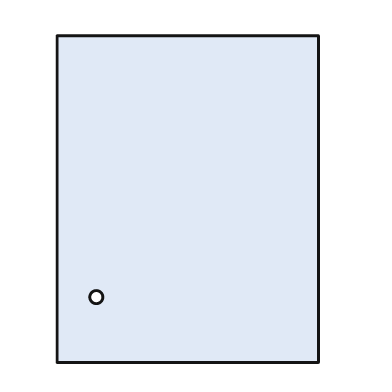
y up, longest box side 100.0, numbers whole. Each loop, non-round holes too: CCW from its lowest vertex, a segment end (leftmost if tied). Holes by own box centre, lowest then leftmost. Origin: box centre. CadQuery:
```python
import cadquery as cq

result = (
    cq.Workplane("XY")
    .moveTo(-40.0, -50.0)
    .lineTo(40.0, -50.0)
    .lineTo(40.0, 50.0)
    .lineTo(-40.0, 50.0)
    .close()
    .moveTo(-28.0, -30.0)
    .circle(2.0)
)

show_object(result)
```